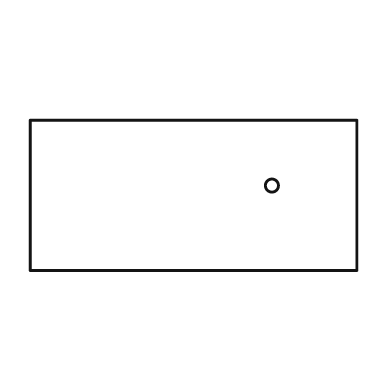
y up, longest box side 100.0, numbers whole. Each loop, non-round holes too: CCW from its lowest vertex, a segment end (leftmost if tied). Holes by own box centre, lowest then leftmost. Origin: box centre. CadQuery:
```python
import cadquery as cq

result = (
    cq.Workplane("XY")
    .moveTo(-50.0, -23.0)
    .lineTo(50.0, -23.0)
    .lineTo(50.0, 23.0)
    .lineTo(-50.0, 23.0)
    .close()
    .moveTo(24.0, 3.0)
    .circle(2.0)
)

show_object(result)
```